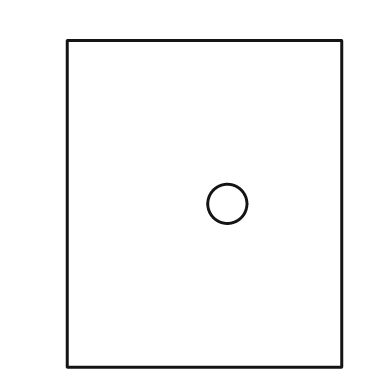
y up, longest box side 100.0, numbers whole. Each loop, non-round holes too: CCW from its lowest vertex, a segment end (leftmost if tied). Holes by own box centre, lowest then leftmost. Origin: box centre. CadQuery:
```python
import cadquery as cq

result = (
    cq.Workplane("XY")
    .moveTo(-42.0, -50.0)
    .lineTo(42.0, -50.0)
    .lineTo(42.0, 50.0)
    .lineTo(-42.0, 50.0)
    .close()
    .moveTo(7.0, 0.0)
    .circle(6.0)
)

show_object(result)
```